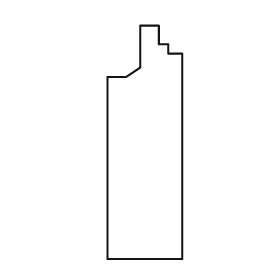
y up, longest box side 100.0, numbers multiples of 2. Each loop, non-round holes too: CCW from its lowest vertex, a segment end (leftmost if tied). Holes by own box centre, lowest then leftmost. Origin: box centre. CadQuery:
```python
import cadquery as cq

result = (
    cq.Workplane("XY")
    .moveTo(-16.0, -50.0)
    .lineTo(16.0, -50.0)
    .lineTo(16.0, 38.0)
    .lineTo(10.0, 38.0)
    .lineTo(10.0, 42.0)
    .lineTo(6.0, 42.0)
    .lineTo(6.0, 50.0)
    .lineTo(-2.0, 50.0)
    .lineTo(-2.0, 32.0)
    .lineTo(-8.0, 28.0)
    .lineTo(-16.0, 28.0)
    .close()
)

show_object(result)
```